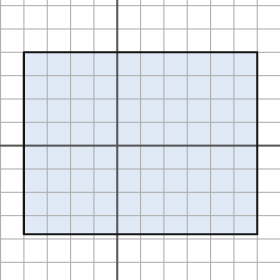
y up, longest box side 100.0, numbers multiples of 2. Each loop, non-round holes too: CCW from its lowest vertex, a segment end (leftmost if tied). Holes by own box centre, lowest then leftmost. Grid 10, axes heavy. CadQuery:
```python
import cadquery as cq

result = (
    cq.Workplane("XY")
    .moveTo(-40.0, -38.0)
    .lineTo(60.0, -38.0)
    .lineTo(60.0, 40.0)
    .lineTo(-40.0, 40.0)
    .close()
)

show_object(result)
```